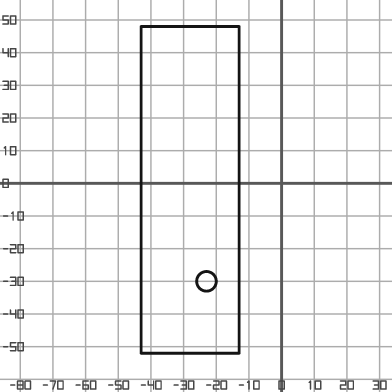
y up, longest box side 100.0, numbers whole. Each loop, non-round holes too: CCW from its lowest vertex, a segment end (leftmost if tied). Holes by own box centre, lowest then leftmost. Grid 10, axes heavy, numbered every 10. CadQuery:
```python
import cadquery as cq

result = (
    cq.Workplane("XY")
    .moveTo(-43.0, -52.0)
    .lineTo(-13.0, -52.0)
    .lineTo(-13.0, 48.0)
    .lineTo(-43.0, 48.0)
    .close()
    .moveTo(-23.0, -30.0)
    .circle(3.0)
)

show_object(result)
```